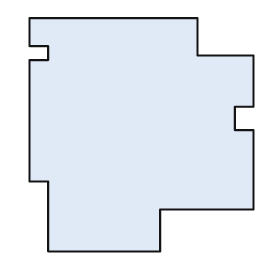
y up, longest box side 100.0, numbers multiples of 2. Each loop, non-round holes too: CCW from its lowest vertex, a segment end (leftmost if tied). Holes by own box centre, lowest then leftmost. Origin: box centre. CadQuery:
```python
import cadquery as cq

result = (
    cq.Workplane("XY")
    .moveTo(-40.0, -50.0)
    .lineTo(8.0, -50.0)
    .lineTo(8.0, -32.0)
    .lineTo(48.0, -32.0)
    .lineTo(48.0, 2.0)
    .lineTo(40.0, 2.0)
    .lineTo(40.0, 12.0)
    .lineTo(48.0, 12.0)
    .lineTo(48.0, 34.0)
    .lineTo(24.0, 34.0)
    .lineTo(24.0, 50.0)
    .lineTo(-48.0, 50.0)
    .lineTo(-48.0, 38.0)
    .lineTo(-40.0, 38.0)
    .lineTo(-40.0, 32.0)
    .lineTo(-48.0, 32.0)
    .lineTo(-48.0, -20.0)
    .lineTo(-40.0, -20.0)
    .close()
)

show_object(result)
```